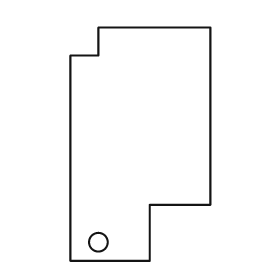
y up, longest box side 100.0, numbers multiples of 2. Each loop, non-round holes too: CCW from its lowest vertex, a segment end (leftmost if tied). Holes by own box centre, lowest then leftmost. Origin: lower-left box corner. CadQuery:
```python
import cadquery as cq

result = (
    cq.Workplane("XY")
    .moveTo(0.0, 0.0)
    .lineTo(34.0, 0.0)
    .lineTo(34.0, 24.0)
    .lineTo(60.0, 24.0)
    .lineTo(60.0, 100.0)
    .lineTo(12.0, 100.0)
    .lineTo(12.0, 88.0)
    .lineTo(0.0, 88.0)
    .close()
    .moveTo(12.0, 8.0)
    .circle(4.0)
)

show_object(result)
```